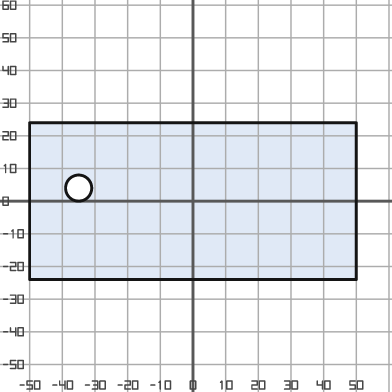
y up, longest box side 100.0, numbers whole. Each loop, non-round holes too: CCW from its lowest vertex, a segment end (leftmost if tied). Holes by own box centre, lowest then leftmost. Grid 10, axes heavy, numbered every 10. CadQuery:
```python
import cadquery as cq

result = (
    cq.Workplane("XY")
    .moveTo(-50.0, -24.0)
    .lineTo(50.0, -24.0)
    .lineTo(50.0, 24.0)
    .lineTo(-50.0, 24.0)
    .close()
    .moveTo(-35.0, 4.0)
    .circle(4.0)
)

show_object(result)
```